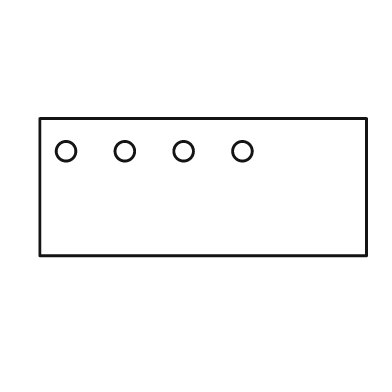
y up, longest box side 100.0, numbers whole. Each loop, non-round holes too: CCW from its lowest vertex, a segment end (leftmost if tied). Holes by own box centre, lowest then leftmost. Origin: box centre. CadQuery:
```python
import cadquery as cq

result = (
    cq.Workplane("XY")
    .moveTo(-50.0, -21.0)
    .lineTo(50.0, -21.0)
    .lineTo(50.0, 21.0)
    .lineTo(-50.0, 21.0)
    .close()
    .moveTo(-42.0, 11.0)
    .circle(3.0)
    .moveTo(-24.0, 11.0)
    .circle(3.0)
    .moveTo(-6.0, 11.0)
    .circle(3.0)
    .moveTo(12.0, 11.0)
    .circle(3.0)
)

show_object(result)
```